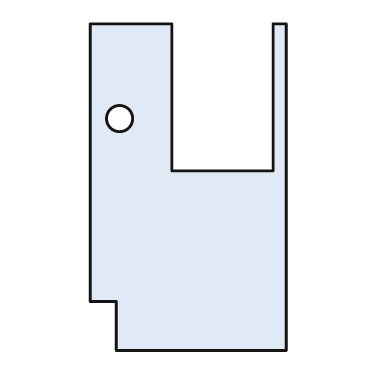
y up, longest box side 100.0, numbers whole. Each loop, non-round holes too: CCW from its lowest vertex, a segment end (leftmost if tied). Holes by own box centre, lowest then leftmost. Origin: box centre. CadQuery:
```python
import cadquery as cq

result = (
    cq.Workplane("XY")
    .moveTo(-22.0, -50.0)
    .lineTo(30.0, -50.0)
    .lineTo(30.0, 50.0)
    .lineTo(26.0, 50.0)
    .lineTo(26.0, 5.0)
    .lineTo(-5.0, 5.0)
    .lineTo(-5.0, 50.0)
    .lineTo(-30.0, 50.0)
    .lineTo(-30.0, -35.0)
    .lineTo(-22.0, -35.0)
    .close()
    .moveTo(-21.0, 21.0)
    .circle(4.0)
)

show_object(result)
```